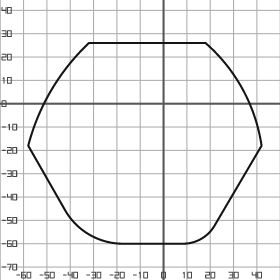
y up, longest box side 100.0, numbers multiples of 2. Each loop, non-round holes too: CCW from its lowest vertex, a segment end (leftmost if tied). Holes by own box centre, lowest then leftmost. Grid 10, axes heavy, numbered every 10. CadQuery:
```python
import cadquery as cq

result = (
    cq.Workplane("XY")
    .moveTo(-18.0, -60.0)
    .lineTo(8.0, -60.0)
    .threePointArc((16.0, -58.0), (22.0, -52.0))
    .lineTo(42.0, -18.0)
    .threePointArc((34.0, 6.0), (18.0, 26.0))
    .lineTo(-32.0, 26.0)
    .threePointArc((-48.0, 6.0), (-58.0, -18.0))
    .lineTo(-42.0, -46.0)
    .threePointArc((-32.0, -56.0), (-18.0, -60.0))
    .close()
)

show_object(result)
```